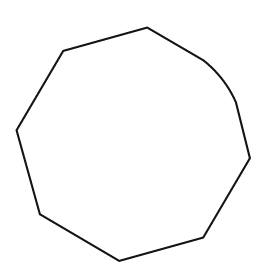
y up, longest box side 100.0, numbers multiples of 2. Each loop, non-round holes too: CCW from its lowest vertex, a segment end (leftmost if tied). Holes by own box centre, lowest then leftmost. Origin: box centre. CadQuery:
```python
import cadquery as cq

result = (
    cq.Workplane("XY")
    .moveTo(-6.0, -50.0)
    .lineTo(30.0, -40.0)
    .lineTo(50.0, -6.0)
    .lineTo(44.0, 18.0)
    .threePointArc((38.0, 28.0), (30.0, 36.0))
    .lineTo(6.0, 50.0)
    .lineTo(-30.0, 40.0)
    .lineTo(-50.0, 6.0)
    .lineTo(-40.0, -30.0)
    .close()
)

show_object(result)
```